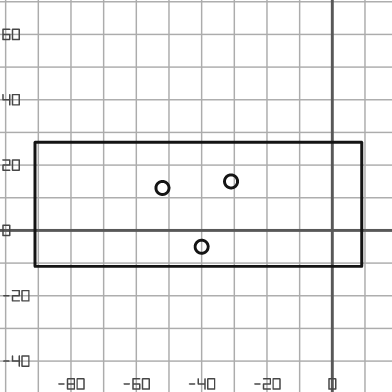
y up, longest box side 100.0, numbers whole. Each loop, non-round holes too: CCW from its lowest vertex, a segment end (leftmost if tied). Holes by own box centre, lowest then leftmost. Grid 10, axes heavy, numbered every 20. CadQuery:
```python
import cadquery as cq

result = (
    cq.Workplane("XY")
    .moveTo(-91.0, -11.0)
    .lineTo(9.0, -11.0)
    .lineTo(9.0, 27.0)
    .lineTo(-91.0, 27.0)
    .close()
    .moveTo(-40.0, -5.0)
    .circle(2.0)
    .moveTo(-52.0, 13.0)
    .circle(2.0)
    .moveTo(-31.0, 15.0)
    .circle(2.0)
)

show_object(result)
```